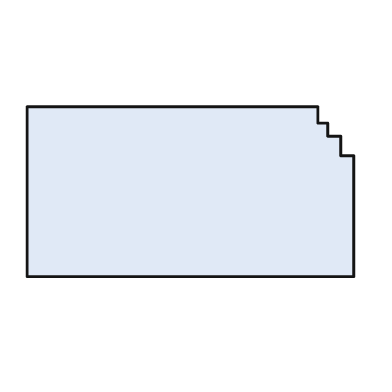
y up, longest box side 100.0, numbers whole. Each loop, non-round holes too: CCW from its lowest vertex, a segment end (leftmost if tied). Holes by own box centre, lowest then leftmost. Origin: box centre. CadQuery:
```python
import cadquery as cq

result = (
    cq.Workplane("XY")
    .moveTo(-50.0, -26.0)
    .lineTo(50.0, -26.0)
    .lineTo(50.0, 11.0)
    .lineTo(46.0, 11.0)
    .lineTo(46.0, 17.0)
    .lineTo(42.0, 17.0)
    .lineTo(42.0, 21.0)
    .lineTo(39.0, 21.0)
    .lineTo(39.0, 26.0)
    .lineTo(-50.0, 26.0)
    .close()
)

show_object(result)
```